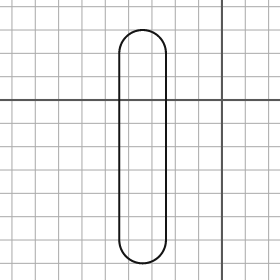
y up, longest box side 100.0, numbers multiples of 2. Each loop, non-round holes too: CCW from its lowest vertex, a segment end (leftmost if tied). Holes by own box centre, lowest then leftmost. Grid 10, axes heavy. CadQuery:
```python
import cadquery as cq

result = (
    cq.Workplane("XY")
    .moveTo(-44.0, -60.0)
    .threePointArc((-34.0, -70.0), (-24.0, -60.0))
    .lineTo(-24.0, 20.0)
    .threePointArc((-34.0, 30.0), (-44.0, 20.0))
    .close()
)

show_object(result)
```